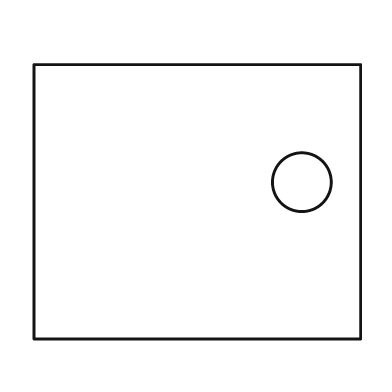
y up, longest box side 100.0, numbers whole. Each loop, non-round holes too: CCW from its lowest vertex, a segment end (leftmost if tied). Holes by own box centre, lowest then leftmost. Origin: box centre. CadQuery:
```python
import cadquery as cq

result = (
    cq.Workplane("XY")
    .moveTo(-50.0, -42.0)
    .lineTo(50.0, -42.0)
    .lineTo(50.0, 42.0)
    .lineTo(-50.0, 42.0)
    .close()
    .moveTo(32.0, 6.0)
    .circle(9.0)
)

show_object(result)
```